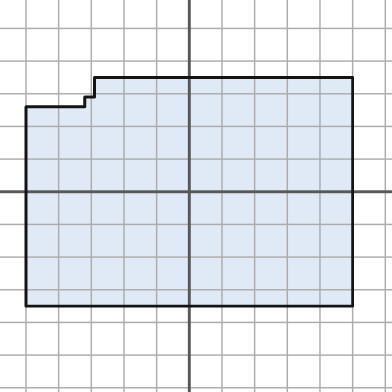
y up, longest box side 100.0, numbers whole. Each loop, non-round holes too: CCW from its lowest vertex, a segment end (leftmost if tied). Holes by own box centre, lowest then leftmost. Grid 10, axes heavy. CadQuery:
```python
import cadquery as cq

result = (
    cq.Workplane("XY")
    .moveTo(-50.0, -35.0)
    .lineTo(50.0, -35.0)
    .lineTo(50.0, 35.0)
    .lineTo(-29.0, 35.0)
    .lineTo(-29.0, 29.0)
    .lineTo(-32.0, 29.0)
    .lineTo(-32.0, 26.0)
    .lineTo(-50.0, 26.0)
    .close()
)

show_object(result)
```